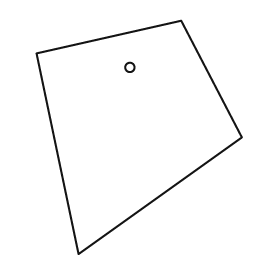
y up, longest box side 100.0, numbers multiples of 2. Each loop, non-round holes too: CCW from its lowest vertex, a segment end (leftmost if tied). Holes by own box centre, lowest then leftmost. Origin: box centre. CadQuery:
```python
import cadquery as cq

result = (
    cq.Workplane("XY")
    .moveTo(-26.0, -50.0)
    .lineTo(44.0, 0.0)
    .lineTo(18.0, 50.0)
    .lineTo(-44.0, 36.0)
    .close()
    .moveTo(-4.0, 30.0)
    .circle(2.0)
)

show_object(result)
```